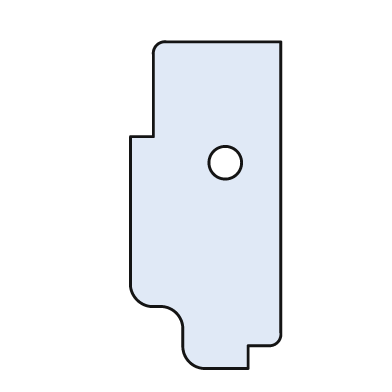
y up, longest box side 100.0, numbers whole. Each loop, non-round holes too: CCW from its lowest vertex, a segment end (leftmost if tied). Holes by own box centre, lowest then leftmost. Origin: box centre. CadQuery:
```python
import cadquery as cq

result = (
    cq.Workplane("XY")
    .moveTo(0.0, -50.0)
    .lineTo(13.0, -50.0)
    .lineTo(13.0, -43.0)
    .lineTo(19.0, -43.0)
    .threePointArc((22.0, -42.0), (23.0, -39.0))
    .lineTo(23.0, 50.0)
    .lineTo(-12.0, 50.0)
    .threePointArc((-15.0, 49.0), (-16.0, 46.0))
    .lineTo(-16.0, 21.0)
    .lineTo(-23.0, 21.0)
    .lineTo(-23.0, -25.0)
    .threePointArc((-21.0, -29.0), (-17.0, -31.0))
    .lineTo(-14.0, -31.0)
    .threePointArc((-9.0, -33.0), (-7.0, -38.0))
    .lineTo(-7.0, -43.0)
    .threePointArc((-5.0, -48.0), (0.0, -50.0))
    .close()
    .moveTo(6.0, 13.0)
    .circle(5.0)
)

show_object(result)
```